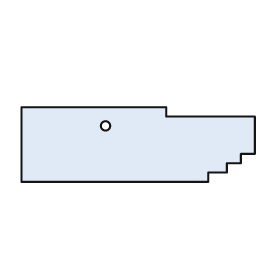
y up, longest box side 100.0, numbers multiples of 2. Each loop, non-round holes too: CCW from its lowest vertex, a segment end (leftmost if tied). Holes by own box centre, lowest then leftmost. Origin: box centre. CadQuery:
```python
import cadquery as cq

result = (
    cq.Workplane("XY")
    .moveTo(-50.0, -16.0)
    .lineTo(30.0, -16.0)
    .lineTo(30.0, -12.0)
    .lineTo(38.0, -12.0)
    .lineTo(38.0, -8.0)
    .lineTo(44.0, -8.0)
    .lineTo(44.0, -4.0)
    .lineTo(50.0, -4.0)
    .lineTo(50.0, 12.0)
    .lineTo(12.0, 12.0)
    .lineTo(12.0, 16.0)
    .lineTo(-50.0, 16.0)
    .close()
    .moveTo(-14.0, 8.0)
    .circle(2.0)
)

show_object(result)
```